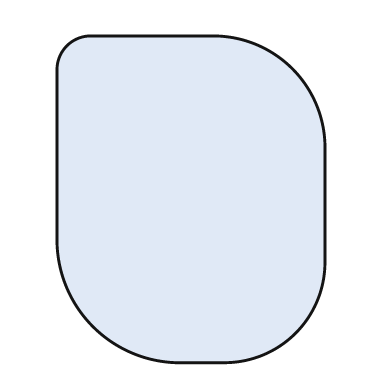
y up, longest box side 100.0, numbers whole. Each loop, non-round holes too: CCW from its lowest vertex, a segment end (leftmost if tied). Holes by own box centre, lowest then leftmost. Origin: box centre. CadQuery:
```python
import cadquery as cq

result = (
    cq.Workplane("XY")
    .moveTo(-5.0, -50.0)
    .lineTo(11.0, -50.0)
    .threePointArc((32.0, -41.0), (41.0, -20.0))
    .lineTo(41.0, 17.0)
    .threePointArc((31.0, 40.0), (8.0, 50.0))
    .lineTo(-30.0, 50.0)
    .threePointArc((-38.0, 47.0), (-41.0, 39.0))
    .lineTo(-41.0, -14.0)
    .threePointArc((-30.0, -39.0), (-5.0, -50.0))
    .close()
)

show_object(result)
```